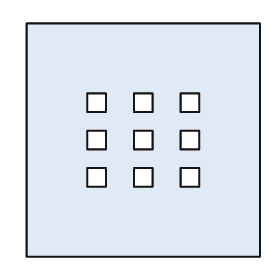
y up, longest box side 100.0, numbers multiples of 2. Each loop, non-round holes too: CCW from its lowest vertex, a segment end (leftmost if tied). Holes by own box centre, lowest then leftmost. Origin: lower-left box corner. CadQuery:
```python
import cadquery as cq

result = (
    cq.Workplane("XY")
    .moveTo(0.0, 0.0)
    .lineTo(100.0, 0.0)
    .lineTo(100.0, 100.0)
    .lineTo(0.0, 100.0)
    .close()
    .moveTo(26.0, 30.0)
    .lineTo(34.0, 30.0)
    .lineTo(34.0, 38.0)
    .lineTo(26.0, 38.0)
    .close()
    .moveTo(46.0, 30.0)
    .lineTo(54.0, 30.0)
    .lineTo(54.0, 38.0)
    .lineTo(46.0, 38.0)
    .close()
    .moveTo(66.0, 30.0)
    .lineTo(74.0, 30.0)
    .lineTo(74.0, 38.0)
    .lineTo(66.0, 38.0)
    .close()
    .moveTo(26.0, 46.0)
    .lineTo(34.0, 46.0)
    .lineTo(34.0, 54.0)
    .lineTo(26.0, 54.0)
    .close()
    .moveTo(46.0, 46.0)
    .lineTo(54.0, 46.0)
    .lineTo(54.0, 54.0)
    .lineTo(46.0, 54.0)
    .close()
    .moveTo(66.0, 46.0)
    .lineTo(74.0, 46.0)
    .lineTo(74.0, 54.0)
    .lineTo(66.0, 54.0)
    .close()
    .moveTo(26.0, 62.0)
    .lineTo(34.0, 62.0)
    .lineTo(34.0, 70.0)
    .lineTo(26.0, 70.0)
    .close()
    .moveTo(46.0, 62.0)
    .lineTo(54.0, 62.0)
    .lineTo(54.0, 70.0)
    .lineTo(46.0, 70.0)
    .close()
    .moveTo(66.0, 62.0)
    .lineTo(74.0, 62.0)
    .lineTo(74.0, 70.0)
    .lineTo(66.0, 70.0)
    .close()
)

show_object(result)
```